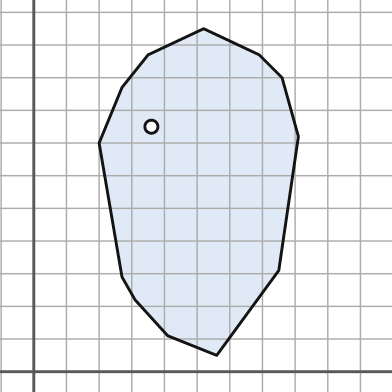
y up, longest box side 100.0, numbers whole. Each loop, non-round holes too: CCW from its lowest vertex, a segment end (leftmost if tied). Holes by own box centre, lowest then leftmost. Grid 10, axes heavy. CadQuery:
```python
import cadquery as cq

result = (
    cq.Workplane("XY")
    .moveTo(56.0, 5.0)
    .lineTo(75.0, 31.0)
    .lineTo(81.0, 72.0)
    .lineTo(76.0, 90.0)
    .lineTo(69.0, 97.0)
    .lineTo(52.0, 105.0)
    .lineTo(35.0, 97.0)
    .lineTo(27.0, 87.0)
    .lineTo(20.0, 70.0)
    .lineTo(27.0, 29.0)
    .lineTo(31.0, 22.0)
    .lineTo(41.0, 11.0)
    .close()
    .moveTo(36.0, 75.0)
    .circle(2.0)
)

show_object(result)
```